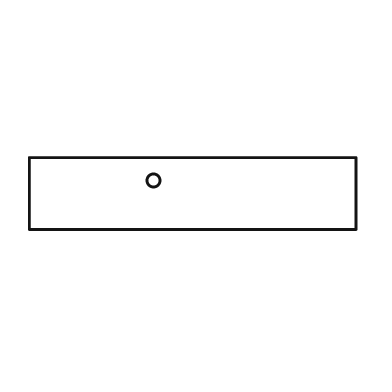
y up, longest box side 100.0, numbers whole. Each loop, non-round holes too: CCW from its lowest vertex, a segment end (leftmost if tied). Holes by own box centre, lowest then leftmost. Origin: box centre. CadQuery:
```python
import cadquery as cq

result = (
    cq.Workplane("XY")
    .moveTo(-50.0, -11.0)
    .lineTo(50.0, -11.0)
    .lineTo(50.0, 11.0)
    .lineTo(-50.0, 11.0)
    .close()
    .moveTo(-12.0, 4.0)
    .circle(2.0)
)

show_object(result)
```